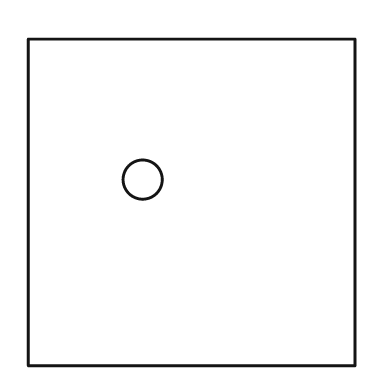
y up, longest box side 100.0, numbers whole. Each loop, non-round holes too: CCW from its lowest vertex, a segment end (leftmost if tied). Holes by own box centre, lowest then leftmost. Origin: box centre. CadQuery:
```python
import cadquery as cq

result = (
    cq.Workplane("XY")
    .moveTo(-50.0, -50.0)
    .lineTo(50.0, -50.0)
    .lineTo(50.0, 50.0)
    .lineTo(-50.0, 50.0)
    .close()
    .moveTo(-15.0, 7.0)
    .circle(6.0)
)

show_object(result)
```